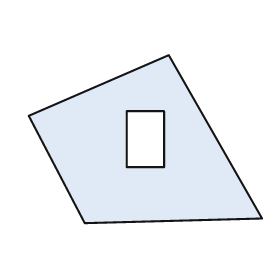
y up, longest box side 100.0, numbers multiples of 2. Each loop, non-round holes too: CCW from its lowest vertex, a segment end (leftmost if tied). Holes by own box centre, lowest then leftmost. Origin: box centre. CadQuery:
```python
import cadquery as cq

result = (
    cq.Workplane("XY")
    .moveTo(-26.0, -36.0)
    .lineTo(50.0, -34.0)
    .lineTo(10.0, 36.0)
    .lineTo(-50.0, 10.0)
    .close()
    .moveTo(-8.0, -12.0)
    .lineTo(8.0, -12.0)
    .lineTo(8.0, 12.0)
    .lineTo(-8.0, 12.0)
    .close()
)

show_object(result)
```